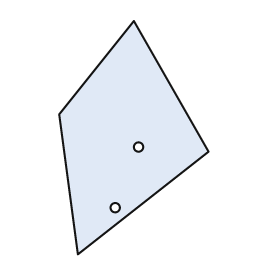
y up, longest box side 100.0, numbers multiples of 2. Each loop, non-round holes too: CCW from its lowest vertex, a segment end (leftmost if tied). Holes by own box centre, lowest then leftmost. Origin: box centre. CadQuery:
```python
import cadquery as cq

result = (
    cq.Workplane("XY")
    .moveTo(-24.0, -50.0)
    .lineTo(32.0, -6.0)
    .lineTo(0.0, 50.0)
    .lineTo(-32.0, 10.0)
    .close()
    .moveTo(-8.0, -30.0)
    .circle(2.0)
    .moveTo(2.0, -4.0)
    .circle(2.0)
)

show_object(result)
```